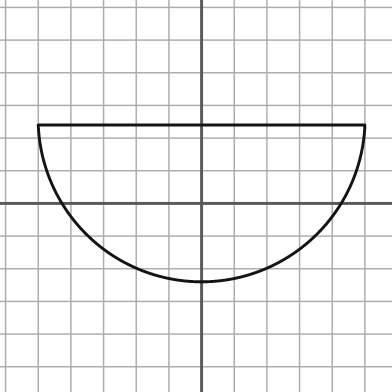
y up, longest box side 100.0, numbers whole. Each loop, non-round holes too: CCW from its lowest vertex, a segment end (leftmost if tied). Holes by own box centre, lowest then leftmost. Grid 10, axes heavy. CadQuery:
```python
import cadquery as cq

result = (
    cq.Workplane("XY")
    .moveTo(-50.0, 24.0)
    .threePointArc((0.0, -24.0), (50.0, 24.0))
    .close()
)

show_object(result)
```